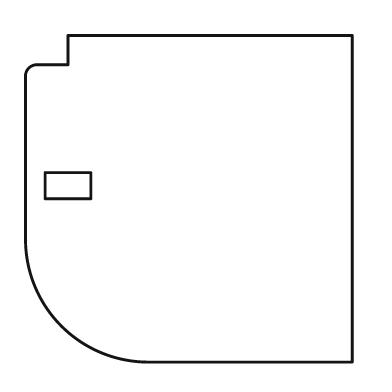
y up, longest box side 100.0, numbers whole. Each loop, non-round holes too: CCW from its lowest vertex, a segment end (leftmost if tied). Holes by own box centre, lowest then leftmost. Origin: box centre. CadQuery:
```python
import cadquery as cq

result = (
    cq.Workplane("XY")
    .moveTo(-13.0, -50.0)
    .lineTo(50.0, -50.0)
    .lineTo(50.0, 50.0)
    .lineTo(-37.0, 50.0)
    .lineTo(-37.0, 41.0)
    .lineTo(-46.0, 41.0)
    .threePointArc((-49.0, 40.0), (-50.0, 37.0))
    .lineTo(-50.0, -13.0)
    .threePointArc((-39.0, -39.0), (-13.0, -50.0))
    .close()
    .moveTo(-44.0, 0.0)
    .lineTo(-30.0, 0.0)
    .lineTo(-30.0, 8.0)
    .lineTo(-44.0, 8.0)
    .close()
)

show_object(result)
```